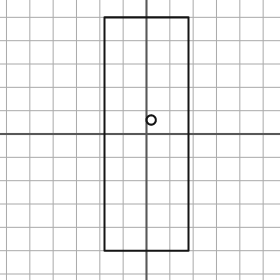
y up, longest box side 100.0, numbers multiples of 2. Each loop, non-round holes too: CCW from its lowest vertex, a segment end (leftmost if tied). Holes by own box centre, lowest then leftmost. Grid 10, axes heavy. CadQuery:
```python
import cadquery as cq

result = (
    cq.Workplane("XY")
    .moveTo(-18.0, -50.0)
    .lineTo(18.0, -50.0)
    .lineTo(18.0, 50.0)
    .lineTo(-18.0, 50.0)
    .close()
    .moveTo(2.0, 6.0)
    .circle(2.0)
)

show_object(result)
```